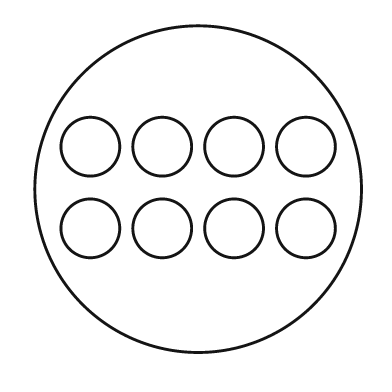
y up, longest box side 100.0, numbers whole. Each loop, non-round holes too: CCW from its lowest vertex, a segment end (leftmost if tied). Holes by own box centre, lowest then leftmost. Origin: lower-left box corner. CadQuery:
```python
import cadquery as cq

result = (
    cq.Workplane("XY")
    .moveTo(50.0, 50.0)
    .circle(50.0)
    .moveTo(17.0, 38.0)
    .circle(9.0)
    .moveTo(39.0, 38.0)
    .circle(9.0)
    .moveTo(61.0, 38.0)
    .circle(9.0)
    .moveTo(83.0, 38.0)
    .circle(9.0)
    .moveTo(17.0, 63.0)
    .circle(9.0)
    .moveTo(39.0, 63.0)
    .circle(9.0)
    .moveTo(61.0, 63.0)
    .circle(9.0)
    .moveTo(83.0, 63.0)
    .circle(9.0)
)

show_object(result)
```